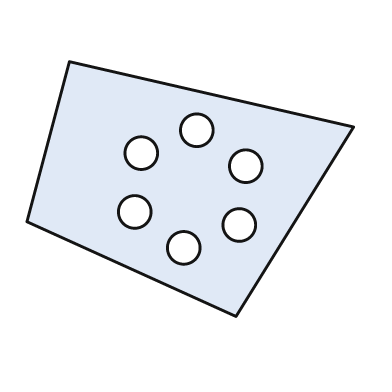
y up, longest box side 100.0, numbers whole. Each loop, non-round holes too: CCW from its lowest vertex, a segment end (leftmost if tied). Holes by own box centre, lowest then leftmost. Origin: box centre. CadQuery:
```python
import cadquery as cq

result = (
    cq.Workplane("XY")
    .moveTo(14.0, -39.0)
    .lineTo(50.0, 19.0)
    .lineTo(-37.0, 39.0)
    .lineTo(-50.0, -10.0)
    .close()
    .moveTo(-2.0, -18.0)
    .circle(5.0)
    .moveTo(15.0, -11.0)
    .circle(5.0)
    .moveTo(-17.0, -7.0)
    .circle(5.0)
    .moveTo(17.0, 7.0)
    .circle(5.0)
    .moveTo(-15.0, 11.0)
    .circle(5.0)
    .moveTo(2.0, 18.0)
    .circle(5.0)
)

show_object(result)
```